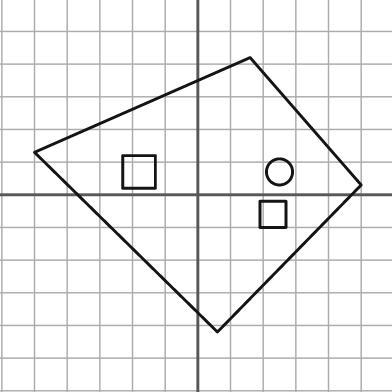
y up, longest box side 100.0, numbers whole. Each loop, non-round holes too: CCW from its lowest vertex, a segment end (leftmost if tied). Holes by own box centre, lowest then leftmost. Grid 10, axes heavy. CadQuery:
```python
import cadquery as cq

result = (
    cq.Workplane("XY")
    .moveTo(6.0, -42.0)
    .lineTo(50.0, 3.0)
    .lineTo(16.0, 42.0)
    .lineTo(-50.0, 13.0)
    .close()
    .moveTo(19.0, -10.0)
    .lineTo(27.0, -10.0)
    .lineTo(27.0, -2.0)
    .lineTo(19.0, -2.0)
    .close()
    .moveTo(-23.0, 2.0)
    .lineTo(-13.0, 2.0)
    .lineTo(-13.0, 12.0)
    .lineTo(-23.0, 12.0)
    .close()
    .moveTo(25.0, 7.0)
    .circle(4.0)
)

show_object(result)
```